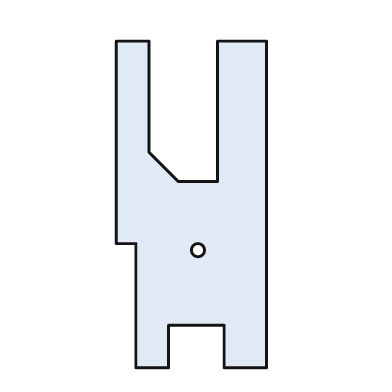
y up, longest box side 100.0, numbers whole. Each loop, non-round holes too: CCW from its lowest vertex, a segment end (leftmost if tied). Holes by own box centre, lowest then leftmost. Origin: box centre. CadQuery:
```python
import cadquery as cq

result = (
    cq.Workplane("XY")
    .moveTo(-17.0, -50.0)
    .lineTo(-7.0, -50.0)
    .lineTo(-7.0, -37.0)
    .lineTo(10.0, -37.0)
    .lineTo(10.0, -50.0)
    .lineTo(23.0, -50.0)
    .lineTo(23.0, 50.0)
    .lineTo(8.0, 50.0)
    .lineTo(8.0, 7.0)
    .lineTo(-4.0, 7.0)
    .lineTo(-13.0, 16.0)
    .lineTo(-13.0, 50.0)
    .lineTo(-23.0, 50.0)
    .lineTo(-23.0, -12.0)
    .lineTo(-17.0, -12.0)
    .close()
    .moveTo(2.0, -14.0)
    .circle(2.0)
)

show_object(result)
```